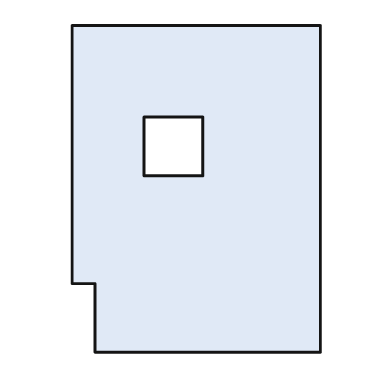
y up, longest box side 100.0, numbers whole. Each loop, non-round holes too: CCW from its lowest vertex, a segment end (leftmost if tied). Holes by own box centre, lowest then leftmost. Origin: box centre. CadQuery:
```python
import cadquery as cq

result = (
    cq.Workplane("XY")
    .moveTo(-31.0, -50.0)
    .lineTo(38.0, -50.0)
    .lineTo(38.0, 50.0)
    .lineTo(-38.0, 50.0)
    .lineTo(-38.0, -29.0)
    .lineTo(-31.0, -29.0)
    .close()
    .moveTo(-16.0, 4.0)
    .lineTo(2.0, 4.0)
    .lineTo(2.0, 22.0)
    .lineTo(-16.0, 22.0)
    .close()
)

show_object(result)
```